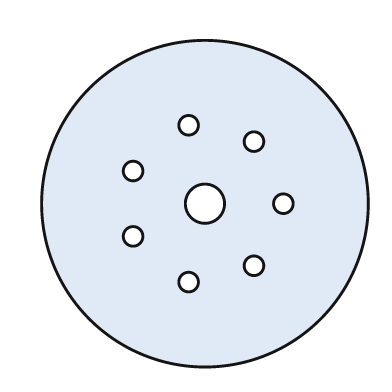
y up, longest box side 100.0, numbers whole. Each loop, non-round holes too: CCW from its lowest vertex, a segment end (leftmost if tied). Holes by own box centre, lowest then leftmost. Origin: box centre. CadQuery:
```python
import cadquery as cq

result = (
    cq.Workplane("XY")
    .moveTo(0.0, 0.0)
    .circle(50.0)
    .moveTo(-5.0, -24.0)
    .circle(3.0)
    .moveTo(15.0, -19.0)
    .circle(3.0)
    .moveTo(-22.0, -10.0)
    .circle(3.0)
    .moveTo(0.0, 0.0)
    .circle(6.0)
    .moveTo(24.0, 0.0)
    .circle(3.0)
    .moveTo(-22.0, 10.0)
    .circle(3.0)
    .moveTo(15.0, 19.0)
    .circle(3.0)
    .moveTo(-5.0, 24.0)
    .circle(3.0)
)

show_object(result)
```